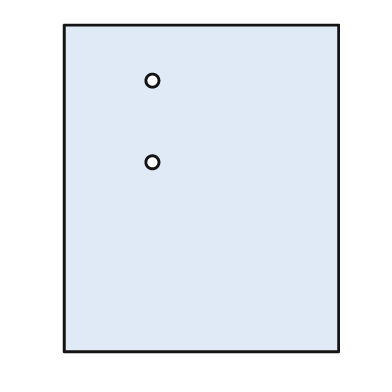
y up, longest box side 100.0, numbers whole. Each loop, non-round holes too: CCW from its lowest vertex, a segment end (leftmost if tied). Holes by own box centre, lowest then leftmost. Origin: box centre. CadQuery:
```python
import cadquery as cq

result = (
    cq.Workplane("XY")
    .moveTo(-42.0, -50.0)
    .lineTo(42.0, -50.0)
    .lineTo(42.0, 50.0)
    .lineTo(-42.0, 50.0)
    .close()
    .moveTo(-15.0, 8.0)
    .circle(2.0)
    .moveTo(-15.0, 33.0)
    .circle(2.0)
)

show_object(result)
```